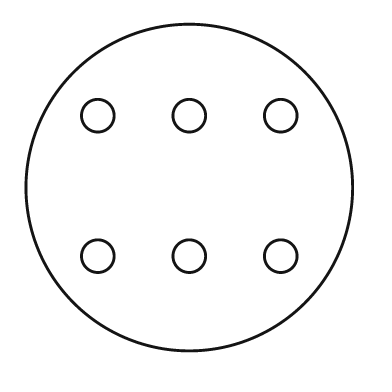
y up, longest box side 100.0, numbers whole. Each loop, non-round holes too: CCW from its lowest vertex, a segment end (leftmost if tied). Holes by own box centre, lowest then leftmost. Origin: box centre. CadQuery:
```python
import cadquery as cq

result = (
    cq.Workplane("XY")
    .moveTo(0.0, 0.0)
    .circle(50.0)
    .moveTo(-28.0, -21.0)
    .circle(5.0)
    .moveTo(0.0, -21.0)
    .circle(5.0)
    .moveTo(28.0, -21.0)
    .circle(5.0)
    .moveTo(-28.0, 22.0)
    .circle(5.0)
    .moveTo(0.0, 22.0)
    .circle(5.0)
    .moveTo(28.0, 22.0)
    .circle(5.0)
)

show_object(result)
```